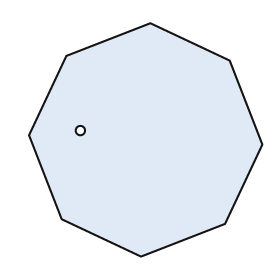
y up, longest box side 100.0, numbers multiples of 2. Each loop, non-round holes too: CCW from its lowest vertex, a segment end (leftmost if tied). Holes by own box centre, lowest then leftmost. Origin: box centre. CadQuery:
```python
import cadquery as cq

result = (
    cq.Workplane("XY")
    .moveTo(-2.0, -50.0)
    .lineTo(34.0, -36.0)
    .lineTo(50.0, -2.0)
    .lineTo(36.0, 34.0)
    .lineTo(2.0, 50.0)
    .lineTo(-34.0, 36.0)
    .lineTo(-50.0, 2.0)
    .lineTo(-36.0, -34.0)
    .close()
    .moveTo(-28.0, 4.0)
    .circle(2.0)
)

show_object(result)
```